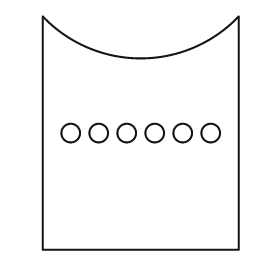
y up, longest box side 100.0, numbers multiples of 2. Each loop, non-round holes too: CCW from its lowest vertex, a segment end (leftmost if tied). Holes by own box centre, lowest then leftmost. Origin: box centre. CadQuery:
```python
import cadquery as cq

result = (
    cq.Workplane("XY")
    .moveTo(-42.0, -50.0)
    .lineTo(42.0, -50.0)
    .lineTo(42.0, 50.0)
    .threePointArc((0.0, 32.0), (-42.0, 50.0))
    .close()
    .moveTo(-30.0, 0.0)
    .circle(4.0)
    .moveTo(-18.0, 0.0)
    .circle(4.0)
    .moveTo(-6.0, 0.0)
    .circle(4.0)
    .moveTo(6.0, 0.0)
    .circle(4.0)
    .moveTo(18.0, 0.0)
    .circle(4.0)
    .moveTo(30.0, 0.0)
    .circle(4.0)
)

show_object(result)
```